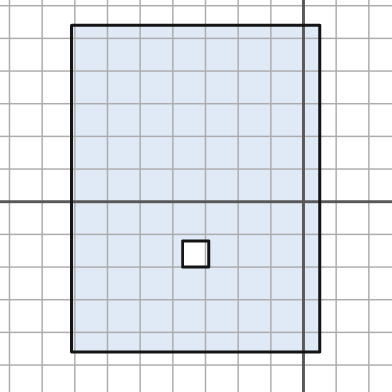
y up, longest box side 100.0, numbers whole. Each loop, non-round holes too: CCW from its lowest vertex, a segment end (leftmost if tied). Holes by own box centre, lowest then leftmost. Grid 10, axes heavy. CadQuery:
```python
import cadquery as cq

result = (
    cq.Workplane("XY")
    .moveTo(-71.0, -46.0)
    .lineTo(5.0, -46.0)
    .lineTo(5.0, 54.0)
    .lineTo(-71.0, 54.0)
    .close()
    .moveTo(-37.0, -20.0)
    .lineTo(-29.0, -20.0)
    .lineTo(-29.0, -12.0)
    .lineTo(-37.0, -12.0)
    .close()
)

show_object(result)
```